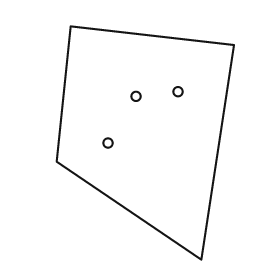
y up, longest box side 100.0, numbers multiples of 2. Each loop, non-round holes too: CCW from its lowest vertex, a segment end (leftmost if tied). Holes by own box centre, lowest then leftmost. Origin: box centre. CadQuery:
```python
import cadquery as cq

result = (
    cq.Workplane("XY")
    .moveTo(24.0, -50.0)
    .lineTo(38.0, 42.0)
    .lineTo(-32.0, 50.0)
    .lineTo(-38.0, -8.0)
    .close()
    .moveTo(-16.0, 0.0)
    .circle(2.0)
    .moveTo(-4.0, 20.0)
    .circle(2.0)
    .moveTo(14.0, 22.0)
    .circle(2.0)
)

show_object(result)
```